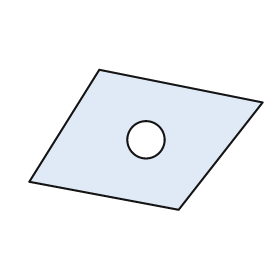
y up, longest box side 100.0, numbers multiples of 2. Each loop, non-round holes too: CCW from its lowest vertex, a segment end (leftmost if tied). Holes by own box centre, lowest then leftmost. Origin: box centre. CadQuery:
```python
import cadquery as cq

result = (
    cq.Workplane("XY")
    .moveTo(14.0, -30.0)
    .lineTo(50.0, 16.0)
    .lineTo(-20.0, 30.0)
    .lineTo(-50.0, -18.0)
    .close()
    .moveTo(0.0, 0.0)
    .circle(8.0)
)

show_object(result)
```